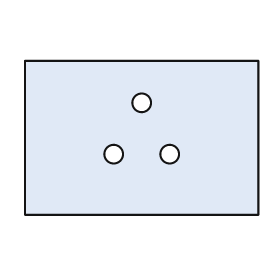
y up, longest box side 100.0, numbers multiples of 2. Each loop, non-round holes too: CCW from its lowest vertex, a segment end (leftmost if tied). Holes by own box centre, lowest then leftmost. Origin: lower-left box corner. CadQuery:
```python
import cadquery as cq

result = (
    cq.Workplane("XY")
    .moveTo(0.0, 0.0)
    .lineTo(100.0, 0.0)
    .lineTo(100.0, 66.0)
    .lineTo(0.0, 66.0)
    .close()
    .moveTo(38.0, 26.0)
    .circle(4.0)
    .moveTo(62.0, 26.0)
    .circle(4.0)
    .moveTo(50.0, 48.0)
    .circle(4.0)
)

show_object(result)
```